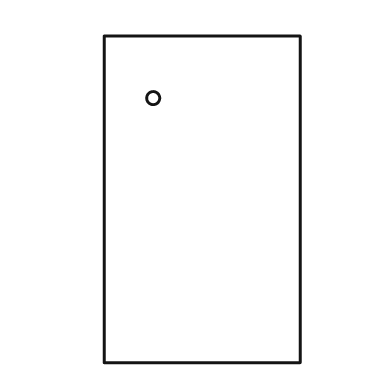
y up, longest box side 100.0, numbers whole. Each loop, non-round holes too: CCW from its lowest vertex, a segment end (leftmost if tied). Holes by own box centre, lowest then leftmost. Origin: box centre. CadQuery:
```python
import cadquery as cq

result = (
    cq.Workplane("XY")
    .moveTo(-30.0, -50.0)
    .lineTo(30.0, -50.0)
    .lineTo(30.0, 50.0)
    .lineTo(-30.0, 50.0)
    .close()
    .moveTo(-15.0, 31.0)
    .circle(2.0)
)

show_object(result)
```